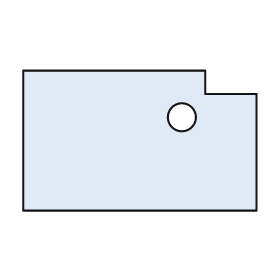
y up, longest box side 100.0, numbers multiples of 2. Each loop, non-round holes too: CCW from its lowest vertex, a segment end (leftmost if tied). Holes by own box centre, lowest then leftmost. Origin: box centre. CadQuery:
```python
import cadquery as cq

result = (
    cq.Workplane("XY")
    .moveTo(-50.0, -30.0)
    .lineTo(50.0, -30.0)
    .lineTo(50.0, 20.0)
    .lineTo(28.0, 20.0)
    .lineTo(28.0, 30.0)
    .lineTo(-50.0, 30.0)
    .close()
    .moveTo(18.0, 10.0)
    .circle(6.0)
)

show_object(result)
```